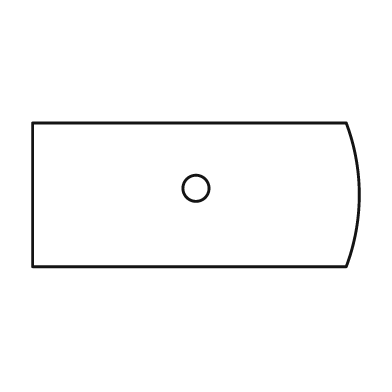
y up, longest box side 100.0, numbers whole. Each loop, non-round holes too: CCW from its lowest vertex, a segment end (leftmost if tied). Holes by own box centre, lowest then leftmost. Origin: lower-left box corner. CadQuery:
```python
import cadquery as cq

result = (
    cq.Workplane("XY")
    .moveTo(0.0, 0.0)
    .lineTo(96.0, 0.0)
    .threePointArc((100.0, 22.0), (96.0, 44.0))
    .lineTo(0.0, 44.0)
    .close()
    .moveTo(50.0, 24.0)
    .circle(4.0)
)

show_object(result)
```